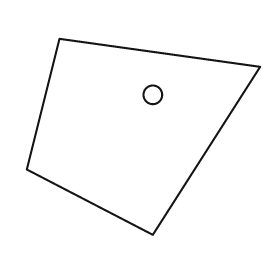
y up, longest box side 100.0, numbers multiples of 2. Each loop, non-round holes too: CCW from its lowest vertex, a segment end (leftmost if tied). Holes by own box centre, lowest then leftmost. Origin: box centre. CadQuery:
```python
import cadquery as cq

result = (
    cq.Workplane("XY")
    .moveTo(4.0, -42.0)
    .lineTo(50.0, 30.0)
    .lineTo(-36.0, 42.0)
    .lineTo(-50.0, -14.0)
    .close()
    .moveTo(4.0, 18.0)
    .circle(4.0)
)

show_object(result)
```